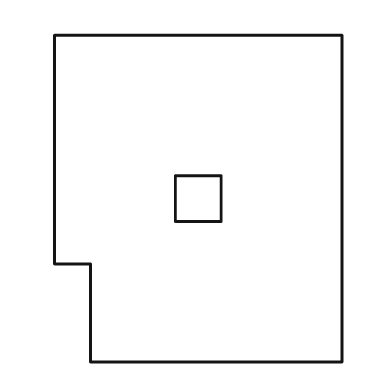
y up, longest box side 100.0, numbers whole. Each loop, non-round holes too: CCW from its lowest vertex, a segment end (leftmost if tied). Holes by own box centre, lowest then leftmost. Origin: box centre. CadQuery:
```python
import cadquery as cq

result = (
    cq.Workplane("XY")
    .moveTo(-33.0, -50.0)
    .lineTo(44.0, -50.0)
    .lineTo(44.0, 50.0)
    .lineTo(-44.0, 50.0)
    .lineTo(-44.0, -20.0)
    .lineTo(-33.0, -20.0)
    .close()
    .moveTo(-7.0, -7.0)
    .lineTo(7.0, -7.0)
    .lineTo(7.0, 7.0)
    .lineTo(-7.0, 7.0)
    .close()
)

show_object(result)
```